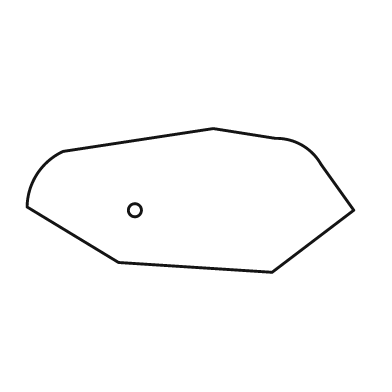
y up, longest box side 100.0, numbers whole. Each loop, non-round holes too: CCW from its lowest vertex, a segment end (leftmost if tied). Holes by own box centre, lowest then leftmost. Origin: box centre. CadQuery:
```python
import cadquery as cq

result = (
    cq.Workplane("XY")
    .moveTo(25.0, -22.0)
    .lineTo(50.0, -3.0)
    .lineTo(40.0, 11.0)
    .threePointArc((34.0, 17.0), (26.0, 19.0))
    .lineTo(7.0, 22.0)
    .lineTo(-39.0, 15.0)
    .threePointArc((-47.0, 8.0), (-50.0, -2.0))
    .lineTo(-22.0, -19.0)
    .close()
    .moveTo(-17.0, -3.0)
    .circle(2.0)
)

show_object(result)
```